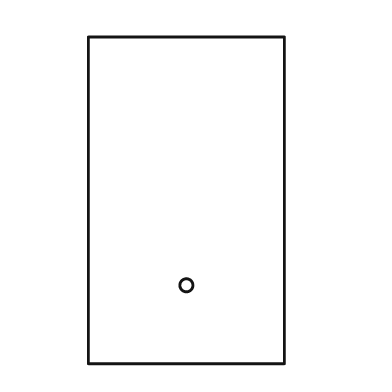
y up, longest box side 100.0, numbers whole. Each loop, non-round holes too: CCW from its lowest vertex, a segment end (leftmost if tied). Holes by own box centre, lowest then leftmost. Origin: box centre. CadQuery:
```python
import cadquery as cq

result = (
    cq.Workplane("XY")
    .moveTo(-30.0, -50.0)
    .lineTo(30.0, -50.0)
    .lineTo(30.0, 50.0)
    .lineTo(-30.0, 50.0)
    .close()
    .moveTo(0.0, -26.0)
    .circle(2.0)
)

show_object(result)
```